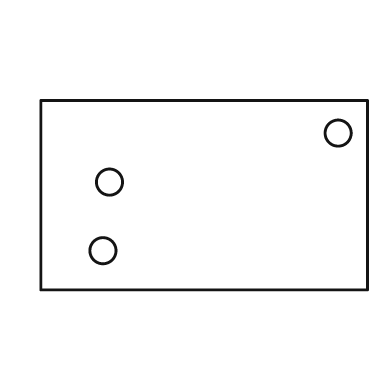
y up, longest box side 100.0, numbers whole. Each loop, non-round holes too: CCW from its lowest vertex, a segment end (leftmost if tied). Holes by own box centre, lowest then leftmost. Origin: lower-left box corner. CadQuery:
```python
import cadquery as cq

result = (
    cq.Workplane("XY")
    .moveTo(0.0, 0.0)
    .lineTo(100.0, 0.0)
    .lineTo(100.0, 58.0)
    .lineTo(0.0, 58.0)
    .close()
    .moveTo(19.0, 12.0)
    .circle(4.0)
    .moveTo(21.0, 33.0)
    .circle(4.0)
    .moveTo(91.0, 48.0)
    .circle(4.0)
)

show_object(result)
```